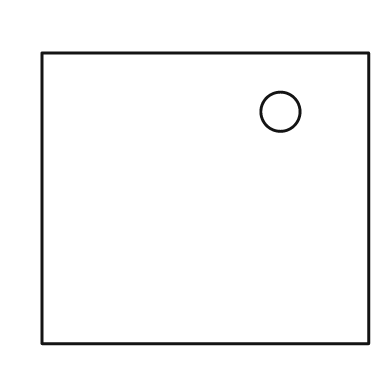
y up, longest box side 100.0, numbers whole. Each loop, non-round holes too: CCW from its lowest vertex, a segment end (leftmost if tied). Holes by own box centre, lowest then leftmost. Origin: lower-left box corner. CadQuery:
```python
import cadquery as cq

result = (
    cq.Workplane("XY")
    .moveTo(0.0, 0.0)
    .lineTo(100.0, 0.0)
    .lineTo(100.0, 89.0)
    .lineTo(0.0, 89.0)
    .close()
    .moveTo(73.0, 71.0)
    .circle(6.0)
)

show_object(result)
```